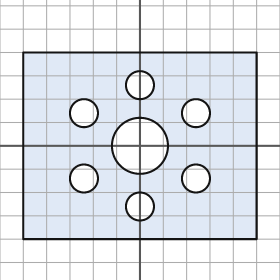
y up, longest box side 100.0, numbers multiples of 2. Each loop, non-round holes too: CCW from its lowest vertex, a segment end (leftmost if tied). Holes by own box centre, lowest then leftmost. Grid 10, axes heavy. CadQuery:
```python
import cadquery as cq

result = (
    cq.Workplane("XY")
    .moveTo(-50.0, -40.0)
    .lineTo(50.0, -40.0)
    .lineTo(50.0, 40.0)
    .lineTo(-50.0, 40.0)
    .close()
    .moveTo(0.0, -26.0)
    .circle(6.0)
    .moveTo(-24.0, -14.0)
    .circle(6.0)
    .moveTo(24.0, -14.0)
    .circle(6.0)
    .moveTo(0.0, 0.0)
    .circle(12.0)
    .moveTo(-24.0, 14.0)
    .circle(6.0)
    .moveTo(24.0, 14.0)
    .circle(6.0)
    .moveTo(0.0, 26.0)
    .circle(6.0)
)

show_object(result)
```